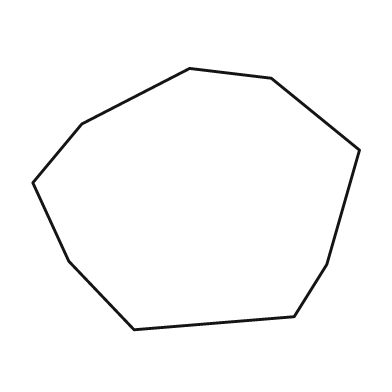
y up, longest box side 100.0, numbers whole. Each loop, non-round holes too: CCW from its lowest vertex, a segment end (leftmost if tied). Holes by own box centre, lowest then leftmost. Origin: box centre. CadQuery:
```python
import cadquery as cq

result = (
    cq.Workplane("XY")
    .moveTo(-19.0, -40.0)
    .lineTo(30.0, -36.0)
    .lineTo(40.0, -20.0)
    .lineTo(50.0, 15.0)
    .lineTo(23.0, 37.0)
    .lineTo(-2.0, 40.0)
    .lineTo(-35.0, 23.0)
    .lineTo(-50.0, 5.0)
    .lineTo(-39.0, -19.0)
    .close()
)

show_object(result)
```